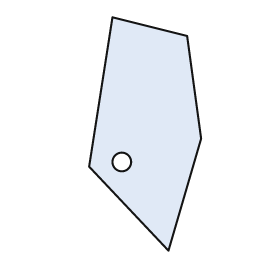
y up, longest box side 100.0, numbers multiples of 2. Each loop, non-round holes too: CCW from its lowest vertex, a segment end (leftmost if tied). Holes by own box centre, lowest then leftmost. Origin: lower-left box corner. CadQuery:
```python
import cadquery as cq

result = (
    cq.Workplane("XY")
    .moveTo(34.0, 0.0)
    .lineTo(48.0, 48.0)
    .lineTo(42.0, 92.0)
    .lineTo(10.0, 100.0)
    .lineTo(0.0, 36.0)
    .close()
    .moveTo(14.0, 38.0)
    .circle(4.0)
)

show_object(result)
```